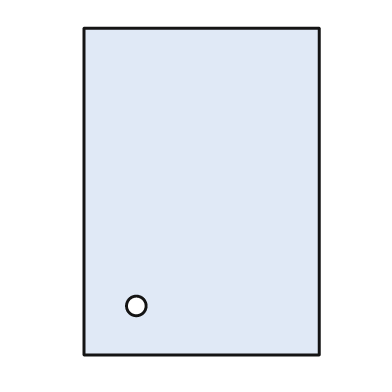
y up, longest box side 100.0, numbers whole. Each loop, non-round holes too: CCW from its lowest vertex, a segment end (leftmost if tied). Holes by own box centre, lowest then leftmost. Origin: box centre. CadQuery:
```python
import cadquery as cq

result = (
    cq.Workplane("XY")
    .moveTo(-36.0, -50.0)
    .lineTo(36.0, -50.0)
    .lineTo(36.0, 50.0)
    .lineTo(-36.0, 50.0)
    .close()
    .moveTo(-20.0, -35.0)
    .circle(3.0)
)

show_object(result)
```